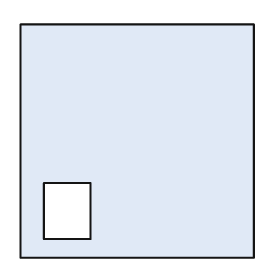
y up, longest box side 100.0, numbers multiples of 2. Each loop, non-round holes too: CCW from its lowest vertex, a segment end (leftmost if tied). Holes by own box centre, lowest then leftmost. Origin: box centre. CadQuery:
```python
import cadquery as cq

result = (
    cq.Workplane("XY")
    .moveTo(-50.0, -50.0)
    .lineTo(50.0, -50.0)
    .lineTo(50.0, 50.0)
    .lineTo(-50.0, 50.0)
    .close()
    .moveTo(-40.0, -42.0)
    .lineTo(-20.0, -42.0)
    .lineTo(-20.0, -18.0)
    .lineTo(-40.0, -18.0)
    .close()
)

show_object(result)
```